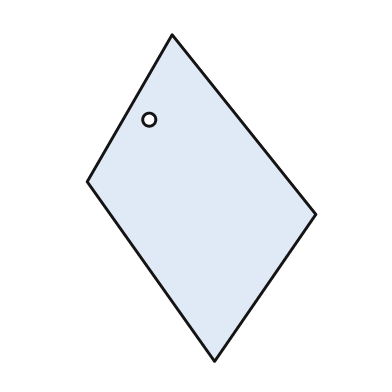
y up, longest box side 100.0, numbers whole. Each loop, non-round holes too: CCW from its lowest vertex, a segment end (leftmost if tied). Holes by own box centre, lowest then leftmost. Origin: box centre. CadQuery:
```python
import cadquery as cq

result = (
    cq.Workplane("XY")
    .moveTo(4.0, -50.0)
    .lineTo(35.0, -5.0)
    .lineTo(-9.0, 50.0)
    .lineTo(-35.0, 5.0)
    .close()
    .moveTo(-16.0, 24.0)
    .circle(2.0)
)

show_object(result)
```